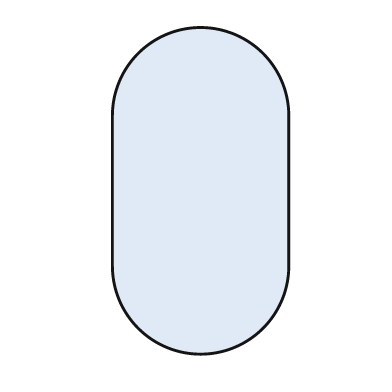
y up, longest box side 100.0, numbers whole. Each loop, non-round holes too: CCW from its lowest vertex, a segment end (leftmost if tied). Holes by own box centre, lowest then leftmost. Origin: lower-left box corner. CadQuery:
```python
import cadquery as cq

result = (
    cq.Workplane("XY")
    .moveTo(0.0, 27.0)
    .threePointArc((27.0, 0.0), (54.0, 27.0))
    .lineTo(54.0, 73.0)
    .threePointArc((27.0, 100.0), (0.0, 73.0))
    .close()
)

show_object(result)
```